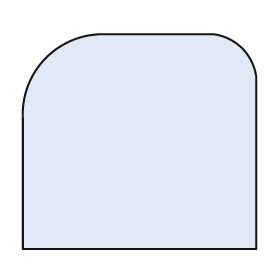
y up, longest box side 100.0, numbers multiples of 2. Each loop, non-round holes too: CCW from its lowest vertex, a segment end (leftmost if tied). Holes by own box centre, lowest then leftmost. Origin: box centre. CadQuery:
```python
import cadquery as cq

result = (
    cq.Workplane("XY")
    .moveTo(-50.0, -46.0)
    .lineTo(50.0, -46.0)
    .lineTo(50.0, 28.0)
    .threePointArc((44.0, 40.0), (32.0, 46.0))
    .lineTo(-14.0, 46.0)
    .threePointArc((-40.0, 36.0), (-50.0, 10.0))
    .close()
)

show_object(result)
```